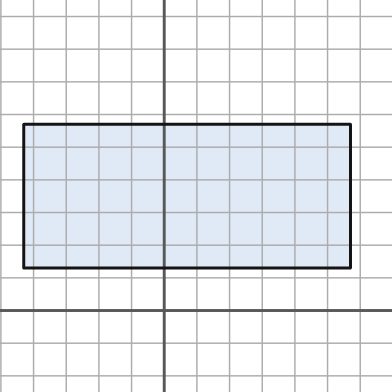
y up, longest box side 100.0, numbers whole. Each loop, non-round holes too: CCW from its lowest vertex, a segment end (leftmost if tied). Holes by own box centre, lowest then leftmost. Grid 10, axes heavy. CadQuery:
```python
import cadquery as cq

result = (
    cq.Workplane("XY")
    .moveTo(-43.0, 13.0)
    .lineTo(57.0, 13.0)
    .lineTo(57.0, 57.0)
    .lineTo(-43.0, 57.0)
    .close()
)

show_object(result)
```